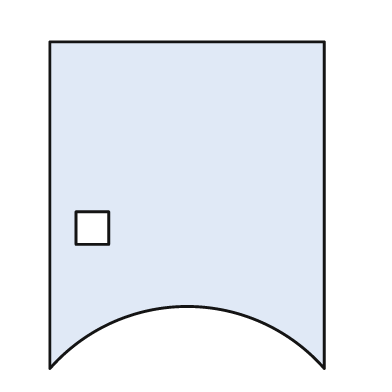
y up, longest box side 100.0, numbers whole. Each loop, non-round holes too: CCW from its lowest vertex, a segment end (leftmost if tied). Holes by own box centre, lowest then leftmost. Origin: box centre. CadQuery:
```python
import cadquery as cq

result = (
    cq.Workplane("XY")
    .moveTo(-42.0, -50.0)
    .threePointArc((0.0, -31.0), (42.0, -50.0))
    .lineTo(42.0, 50.0)
    .lineTo(-42.0, 50.0)
    .close()
    .moveTo(-34.0, -12.0)
    .lineTo(-24.0, -12.0)
    .lineTo(-24.0, -2.0)
    .lineTo(-34.0, -2.0)
    .close()
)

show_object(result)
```